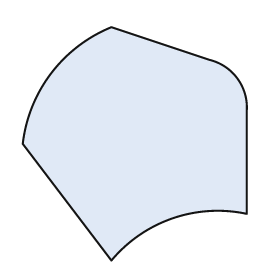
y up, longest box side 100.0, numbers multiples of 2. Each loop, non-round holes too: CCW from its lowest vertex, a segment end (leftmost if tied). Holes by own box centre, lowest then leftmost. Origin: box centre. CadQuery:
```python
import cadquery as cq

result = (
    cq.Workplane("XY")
    .moveTo(-10.0, -50.0)
    .threePointArc((16.0, -32.0), (48.0, -30.0))
    .lineTo(48.0, 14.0)
    .threePointArc((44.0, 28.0), (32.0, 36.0))
    .lineTo(-10.0, 50.0)
    .threePointArc((-36.0, 30.0), (-48.0, 0.0))
    .close()
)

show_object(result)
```